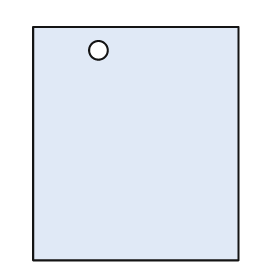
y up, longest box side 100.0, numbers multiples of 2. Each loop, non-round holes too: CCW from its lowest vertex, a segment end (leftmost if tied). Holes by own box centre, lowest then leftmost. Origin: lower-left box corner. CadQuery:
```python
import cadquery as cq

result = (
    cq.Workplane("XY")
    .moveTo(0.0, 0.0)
    .lineTo(88.0, 0.0)
    .lineTo(88.0, 100.0)
    .lineTo(0.0, 100.0)
    .close()
    .moveTo(28.0, 90.0)
    .circle(4.0)
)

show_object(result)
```